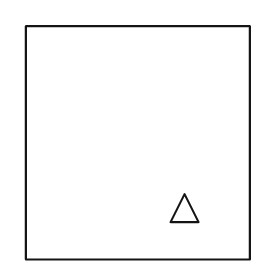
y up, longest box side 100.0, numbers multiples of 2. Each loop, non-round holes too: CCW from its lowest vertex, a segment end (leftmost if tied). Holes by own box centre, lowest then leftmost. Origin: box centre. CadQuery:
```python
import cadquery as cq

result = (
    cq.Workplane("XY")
    .moveTo(-48.0, -50.0)
    .lineTo(48.0, -50.0)
    .lineTo(48.0, 50.0)
    .lineTo(-48.0, 50.0)
    .close()
    .moveTo(14.0, -34.0)
    .lineTo(26.0, -34.0)
    .lineTo(20.0, -22.0)
    .close()
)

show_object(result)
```